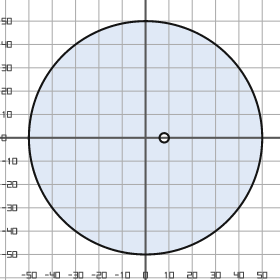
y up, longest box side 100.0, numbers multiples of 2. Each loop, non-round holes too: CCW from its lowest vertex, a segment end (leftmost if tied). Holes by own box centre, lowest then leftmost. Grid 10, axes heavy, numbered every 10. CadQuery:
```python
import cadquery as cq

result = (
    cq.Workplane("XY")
    .moveTo(0.0, 0.0)
    .circle(50.0)
    .moveTo(8.0, 0.0)
    .circle(2.0)
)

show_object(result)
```